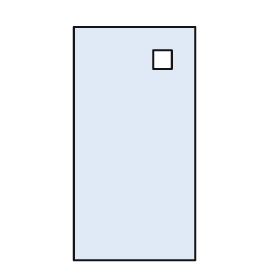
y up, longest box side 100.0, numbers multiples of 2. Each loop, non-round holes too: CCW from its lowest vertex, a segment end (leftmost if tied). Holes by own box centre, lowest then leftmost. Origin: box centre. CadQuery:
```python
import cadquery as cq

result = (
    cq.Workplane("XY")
    .moveTo(-26.0, -50.0)
    .lineTo(26.0, -50.0)
    .lineTo(26.0, 50.0)
    .lineTo(-26.0, 50.0)
    .close()
    .moveTo(8.0, 32.0)
    .lineTo(16.0, 32.0)
    .lineTo(16.0, 40.0)
    .lineTo(8.0, 40.0)
    .close()
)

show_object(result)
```